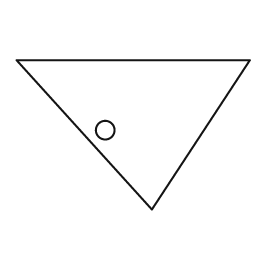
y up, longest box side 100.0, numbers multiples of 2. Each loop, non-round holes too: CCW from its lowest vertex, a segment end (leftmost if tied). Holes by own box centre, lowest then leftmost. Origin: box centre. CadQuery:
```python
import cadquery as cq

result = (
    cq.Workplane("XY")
    .moveTo(8.0, -32.0)
    .lineTo(50.0, 32.0)
    .lineTo(-50.0, 32.0)
    .close()
    .moveTo(-12.0, 2.0)
    .circle(4.0)
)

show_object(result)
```